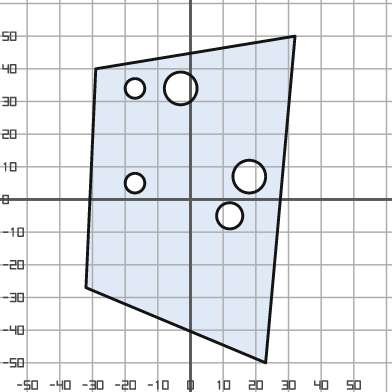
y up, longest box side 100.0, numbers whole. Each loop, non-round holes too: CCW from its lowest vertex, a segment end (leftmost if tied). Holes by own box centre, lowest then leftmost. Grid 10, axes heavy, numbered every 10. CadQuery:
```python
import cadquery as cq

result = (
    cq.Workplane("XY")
    .moveTo(23.0, -50.0)
    .lineTo(32.0, 50.0)
    .lineTo(-29.0, 40.0)
    .lineTo(-32.0, -27.0)
    .close()
    .moveTo(12.0, -5.0)
    .circle(4.0)
    .moveTo(-17.0, 5.0)
    .circle(3.0)
    .moveTo(18.0, 7.0)
    .circle(5.0)
    .moveTo(-17.0, 34.0)
    .circle(3.0)
    .moveTo(-3.0, 34.0)
    .circle(5.0)
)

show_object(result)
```